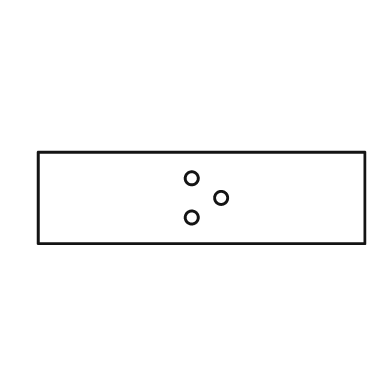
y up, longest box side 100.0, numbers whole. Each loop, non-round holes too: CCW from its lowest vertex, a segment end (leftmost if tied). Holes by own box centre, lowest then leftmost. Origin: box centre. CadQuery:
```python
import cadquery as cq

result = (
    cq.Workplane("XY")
    .moveTo(-50.0, -14.0)
    .lineTo(50.0, -14.0)
    .lineTo(50.0, 14.0)
    .lineTo(-50.0, 14.0)
    .close()
    .moveTo(-3.0, -6.0)
    .circle(2.0)
    .moveTo(6.0, 0.0)
    .circle(2.0)
    .moveTo(-3.0, 6.0)
    .circle(2.0)
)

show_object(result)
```